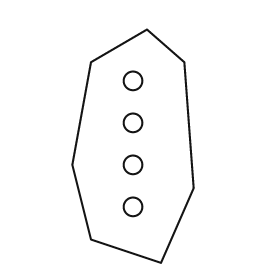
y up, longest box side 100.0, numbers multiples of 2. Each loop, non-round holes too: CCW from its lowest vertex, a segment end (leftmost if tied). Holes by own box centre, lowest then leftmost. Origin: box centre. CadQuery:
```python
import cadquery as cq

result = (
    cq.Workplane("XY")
    .moveTo(12.0, -50.0)
    .lineTo(26.0, -18.0)
    .lineTo(22.0, 36.0)
    .lineTo(6.0, 50.0)
    .lineTo(-18.0, 36.0)
    .lineTo(-26.0, -8.0)
    .lineTo(-18.0, -40.0)
    .close()
    .moveTo(0.0, -26.0)
    .circle(4.0)
    .moveTo(0.0, -8.0)
    .circle(4.0)
    .moveTo(0.0, 10.0)
    .circle(4.0)
    .moveTo(0.0, 28.0)
    .circle(4.0)
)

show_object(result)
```